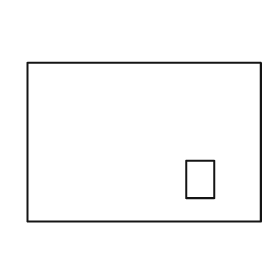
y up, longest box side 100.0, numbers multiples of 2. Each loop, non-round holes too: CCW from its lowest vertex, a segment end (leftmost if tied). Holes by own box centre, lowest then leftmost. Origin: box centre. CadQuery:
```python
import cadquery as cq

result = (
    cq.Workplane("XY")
    .moveTo(-50.0, -34.0)
    .lineTo(50.0, -34.0)
    .lineTo(50.0, 34.0)
    .lineTo(-50.0, 34.0)
    .close()
    .moveTo(18.0, -24.0)
    .lineTo(30.0, -24.0)
    .lineTo(30.0, -8.0)
    .lineTo(18.0, -8.0)
    .close()
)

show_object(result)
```